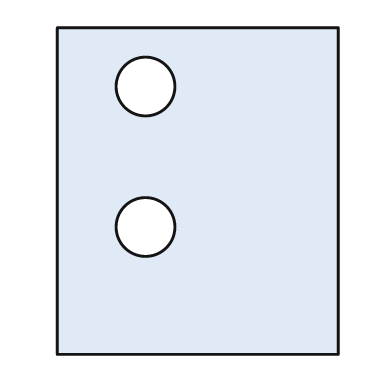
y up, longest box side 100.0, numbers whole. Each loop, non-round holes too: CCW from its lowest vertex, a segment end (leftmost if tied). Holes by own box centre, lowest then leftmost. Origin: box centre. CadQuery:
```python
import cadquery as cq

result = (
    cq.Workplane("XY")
    .moveTo(-43.0, -50.0)
    .lineTo(43.0, -50.0)
    .lineTo(43.0, 50.0)
    .lineTo(-43.0, 50.0)
    .close()
    .moveTo(-16.0, -11.0)
    .circle(9.0)
    .moveTo(-16.0, 32.0)
    .circle(9.0)
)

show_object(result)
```